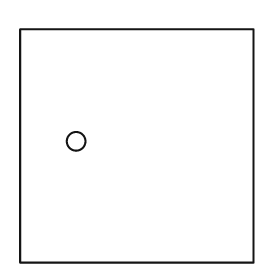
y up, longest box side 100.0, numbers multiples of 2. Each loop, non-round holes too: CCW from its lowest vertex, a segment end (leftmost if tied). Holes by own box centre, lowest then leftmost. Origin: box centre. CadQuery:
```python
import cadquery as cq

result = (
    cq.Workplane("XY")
    .moveTo(-50.0, -50.0)
    .lineTo(50.0, -50.0)
    .lineTo(50.0, 50.0)
    .lineTo(-50.0, 50.0)
    .close()
    .moveTo(-26.0, 2.0)
    .circle(4.0)
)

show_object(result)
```